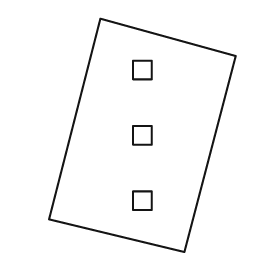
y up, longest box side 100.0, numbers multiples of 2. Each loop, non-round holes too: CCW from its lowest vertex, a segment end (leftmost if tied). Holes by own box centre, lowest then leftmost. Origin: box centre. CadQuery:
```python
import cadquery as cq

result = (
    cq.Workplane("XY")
    .moveTo(18.0, -50.0)
    .lineTo(40.0, 34.0)
    .lineTo(-18.0, 50.0)
    .lineTo(-40.0, -36.0)
    .close()
    .moveTo(-4.0, -32.0)
    .lineTo(4.0, -32.0)
    .lineTo(4.0, -24.0)
    .lineTo(-4.0, -24.0)
    .close()
    .moveTo(-4.0, -4.0)
    .lineTo(4.0, -4.0)
    .lineTo(4.0, 4.0)
    .lineTo(-4.0, 4.0)
    .close()
    .moveTo(-4.0, 24.0)
    .lineTo(4.0, 24.0)
    .lineTo(4.0, 32.0)
    .lineTo(-4.0, 32.0)
    .close()
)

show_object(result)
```